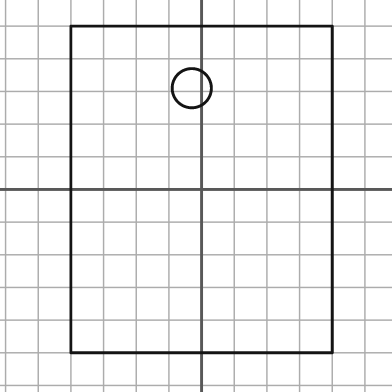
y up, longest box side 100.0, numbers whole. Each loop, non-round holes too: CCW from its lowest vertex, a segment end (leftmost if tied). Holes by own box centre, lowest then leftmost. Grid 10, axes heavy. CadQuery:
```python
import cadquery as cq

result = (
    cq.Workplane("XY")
    .moveTo(-40.0, -50.0)
    .lineTo(40.0, -50.0)
    .lineTo(40.0, 50.0)
    .lineTo(-40.0, 50.0)
    .close()
    .moveTo(-3.0, 31.0)
    .circle(6.0)
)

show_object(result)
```